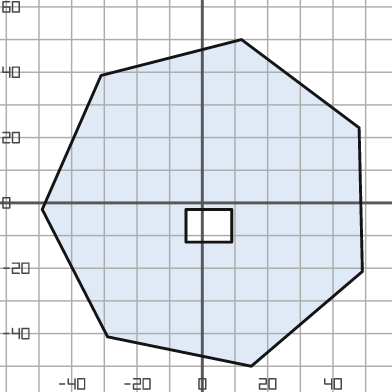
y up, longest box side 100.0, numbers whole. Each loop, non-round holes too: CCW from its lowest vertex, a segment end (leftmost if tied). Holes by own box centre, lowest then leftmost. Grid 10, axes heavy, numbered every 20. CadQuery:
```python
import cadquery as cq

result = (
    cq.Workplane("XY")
    .moveTo(15.0, -50.0)
    .lineTo(49.0, -21.0)
    .lineTo(48.0, 23.0)
    .lineTo(12.0, 50.0)
    .lineTo(-31.0, 39.0)
    .lineTo(-49.0, -2.0)
    .lineTo(-29.0, -41.0)
    .close()
    .moveTo(-5.0, -12.0)
    .lineTo(9.0, -12.0)
    .lineTo(9.0, -2.0)
    .lineTo(-5.0, -2.0)
    .close()
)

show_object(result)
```